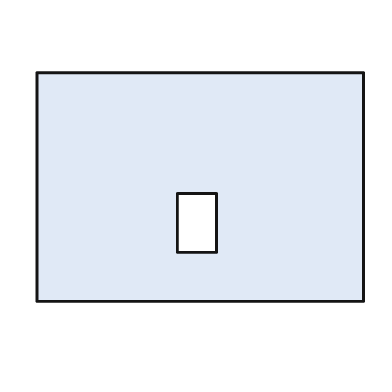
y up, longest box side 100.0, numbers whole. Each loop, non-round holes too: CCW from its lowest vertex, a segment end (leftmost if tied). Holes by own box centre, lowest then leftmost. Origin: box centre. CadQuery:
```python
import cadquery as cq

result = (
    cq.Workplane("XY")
    .moveTo(-50.0, -35.0)
    .lineTo(50.0, -35.0)
    .lineTo(50.0, 35.0)
    .lineTo(-50.0, 35.0)
    .close()
    .moveTo(-7.0, -20.0)
    .lineTo(5.0, -20.0)
    .lineTo(5.0, -2.0)
    .lineTo(-7.0, -2.0)
    .close()
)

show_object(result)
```